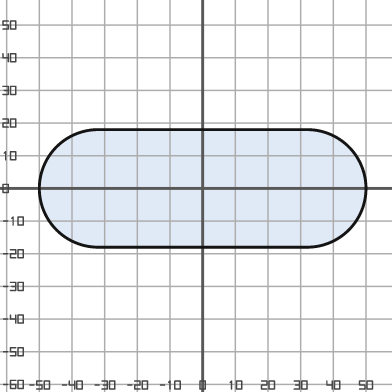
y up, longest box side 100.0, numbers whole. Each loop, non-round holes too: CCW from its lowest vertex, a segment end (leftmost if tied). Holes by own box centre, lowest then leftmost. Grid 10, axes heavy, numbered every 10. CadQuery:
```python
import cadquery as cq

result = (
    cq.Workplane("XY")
    .moveTo(-32.0, -18.0)
    .lineTo(32.0, -18.0)
    .threePointArc((50.0, 0.0), (32.0, 18.0))
    .lineTo(-32.0, 18.0)
    .threePointArc((-50.0, 0.0), (-32.0, -18.0))
    .close()
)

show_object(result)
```